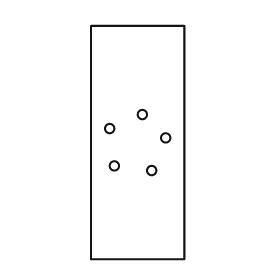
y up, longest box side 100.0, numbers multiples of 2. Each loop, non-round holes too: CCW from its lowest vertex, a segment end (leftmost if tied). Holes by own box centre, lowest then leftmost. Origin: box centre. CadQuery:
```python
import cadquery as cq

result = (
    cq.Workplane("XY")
    .moveTo(-20.0, -50.0)
    .lineTo(20.0, -50.0)
    .lineTo(20.0, 50.0)
    .lineTo(-20.0, 50.0)
    .close()
    .moveTo(6.0, -12.0)
    .circle(2.0)
    .moveTo(-10.0, -10.0)
    .circle(2.0)
    .moveTo(12.0, 2.0)
    .circle(2.0)
    .moveTo(-12.0, 6.0)
    .circle(2.0)
    .moveTo(2.0, 12.0)
    .circle(2.0)
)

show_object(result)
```